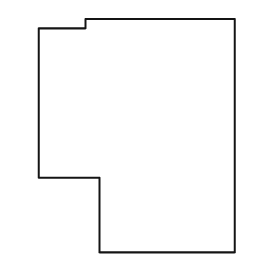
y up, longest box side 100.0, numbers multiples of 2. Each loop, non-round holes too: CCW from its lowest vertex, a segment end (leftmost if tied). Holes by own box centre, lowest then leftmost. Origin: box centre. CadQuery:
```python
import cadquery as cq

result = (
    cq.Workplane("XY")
    .moveTo(-16.0, -50.0)
    .lineTo(42.0, -50.0)
    .lineTo(42.0, 50.0)
    .lineTo(-22.0, 50.0)
    .lineTo(-22.0, 46.0)
    .lineTo(-42.0, 46.0)
    .lineTo(-42.0, -18.0)
    .lineTo(-16.0, -18.0)
    .close()
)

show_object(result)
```